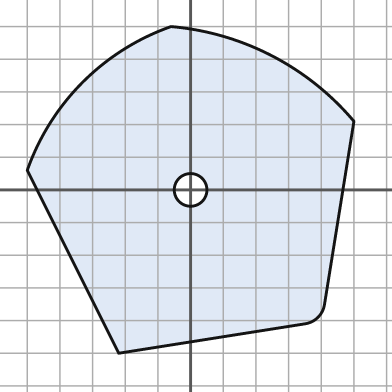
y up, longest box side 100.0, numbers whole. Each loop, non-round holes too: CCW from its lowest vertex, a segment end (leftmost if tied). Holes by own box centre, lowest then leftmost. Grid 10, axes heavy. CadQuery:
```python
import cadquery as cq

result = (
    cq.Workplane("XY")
    .moveTo(-22.0, -50.0)
    .lineTo(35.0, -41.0)
    .threePointArc((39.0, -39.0), (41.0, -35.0))
    .lineTo(50.0, 21.0)
    .threePointArc((25.0, 41.0), (-6.0, 50.0))
    .threePointArc((-33.0, 33.0), (-50.0, 6.0))
    .close()
    .moveTo(0.0, 0.0)
    .circle(5.0)
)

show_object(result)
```